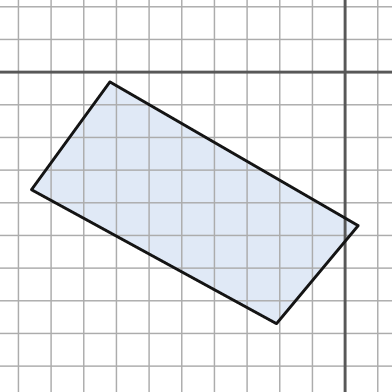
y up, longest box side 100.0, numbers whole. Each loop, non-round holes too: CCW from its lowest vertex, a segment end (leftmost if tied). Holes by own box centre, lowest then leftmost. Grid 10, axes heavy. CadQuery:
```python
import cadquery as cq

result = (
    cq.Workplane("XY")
    .moveTo(-21.0, -77.0)
    .lineTo(4.0, -47.0)
    .lineTo(-72.0, -3.0)
    .lineTo(-96.0, -36.0)
    .close()
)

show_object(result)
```